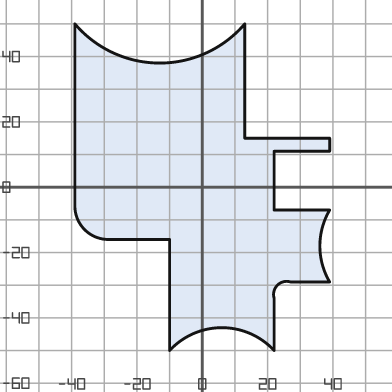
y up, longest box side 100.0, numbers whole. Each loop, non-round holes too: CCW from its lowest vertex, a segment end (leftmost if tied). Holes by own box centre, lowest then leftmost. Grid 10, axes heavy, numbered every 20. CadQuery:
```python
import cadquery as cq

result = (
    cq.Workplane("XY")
    .moveTo(-10.0, -50.0)
    .threePointArc((6.0, -43.0), (22.0, -50.0))
    .lineTo(22.0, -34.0)
    .threePointArc((23.0, -30.0), (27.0, -29.0))
    .lineTo(39.0, -29.0)
    .threePointArc((36.0, -18.0), (39.0, -7.0))
    .lineTo(22.0, -7.0)
    .lineTo(22.0, 11.0)
    .lineTo(39.0, 11.0)
    .lineTo(39.0, 15.0)
    .lineTo(13.0, 15.0)
    .lineTo(13.0, 50.0)
    .threePointArc((-13.0, 38.0), (-39.0, 50.0))
    .lineTo(-39.0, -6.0)
    .threePointArc((-36.0, -13.0), (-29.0, -16.0))
    .lineTo(-10.0, -16.0)
    .close()
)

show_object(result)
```